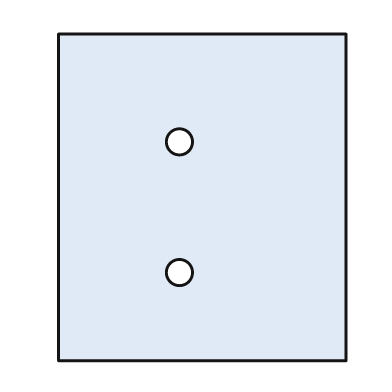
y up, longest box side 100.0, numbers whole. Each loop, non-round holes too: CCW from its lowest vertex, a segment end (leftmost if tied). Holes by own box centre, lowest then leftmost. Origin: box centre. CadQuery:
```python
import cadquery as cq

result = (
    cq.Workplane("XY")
    .moveTo(-44.0, -50.0)
    .lineTo(44.0, -50.0)
    .lineTo(44.0, 50.0)
    .lineTo(-44.0, 50.0)
    .close()
    .moveTo(-7.0, -23.0)
    .circle(4.0)
    .moveTo(-7.0, 17.0)
    .circle(4.0)
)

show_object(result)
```